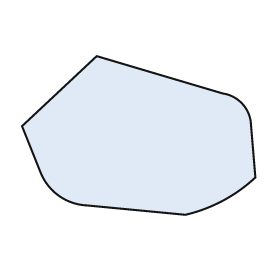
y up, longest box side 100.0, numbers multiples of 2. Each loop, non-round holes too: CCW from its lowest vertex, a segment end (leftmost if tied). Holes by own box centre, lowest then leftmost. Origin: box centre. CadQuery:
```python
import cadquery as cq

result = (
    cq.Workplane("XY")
    .moveTo(20.0, -34.0)
    .threePointArc((36.0, -28.0), (50.0, -18.0))
    .lineTo(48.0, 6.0)
    .threePointArc((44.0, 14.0), (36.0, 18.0))
    .lineTo(-18.0, 34.0)
    .lineTo(-50.0, 4.0)
    .lineTo(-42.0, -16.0)
    .threePointArc((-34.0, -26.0), (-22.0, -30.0))
    .close()
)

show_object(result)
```